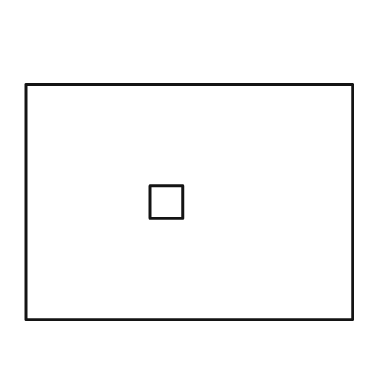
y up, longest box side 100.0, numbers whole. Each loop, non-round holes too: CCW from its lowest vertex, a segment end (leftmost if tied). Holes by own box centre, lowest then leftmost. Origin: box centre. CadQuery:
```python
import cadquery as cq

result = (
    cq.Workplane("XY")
    .moveTo(-50.0, -36.0)
    .lineTo(50.0, -36.0)
    .lineTo(50.0, 36.0)
    .lineTo(-50.0, 36.0)
    .close()
    .moveTo(-12.0, -5.0)
    .lineTo(-2.0, -5.0)
    .lineTo(-2.0, 5.0)
    .lineTo(-12.0, 5.0)
    .close()
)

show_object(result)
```